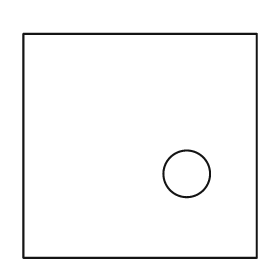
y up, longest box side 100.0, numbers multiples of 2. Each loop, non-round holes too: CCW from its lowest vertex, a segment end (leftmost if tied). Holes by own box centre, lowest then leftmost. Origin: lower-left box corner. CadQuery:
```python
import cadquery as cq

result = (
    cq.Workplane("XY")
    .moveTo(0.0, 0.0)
    .lineTo(100.0, 0.0)
    .lineTo(100.0, 96.0)
    .lineTo(0.0, 96.0)
    .close()
    .moveTo(70.0, 36.0)
    .circle(10.0)
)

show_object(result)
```